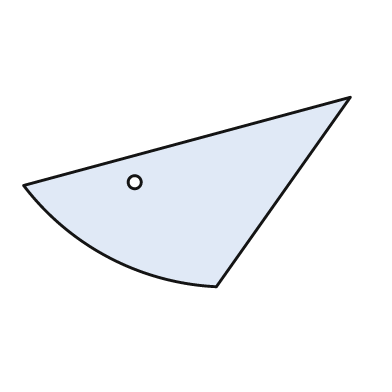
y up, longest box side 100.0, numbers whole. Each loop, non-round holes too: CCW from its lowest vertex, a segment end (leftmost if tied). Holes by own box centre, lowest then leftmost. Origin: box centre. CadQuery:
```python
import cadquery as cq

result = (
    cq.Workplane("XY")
    .moveTo(9.0, -29.0)
    .lineTo(50.0, 29.0)
    .lineTo(-50.0, 2.0)
    .threePointArc((-24.0, -20.0), (9.0, -29.0))
    .close()
    .moveTo(-16.0, 3.0)
    .circle(2.0)
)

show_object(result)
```